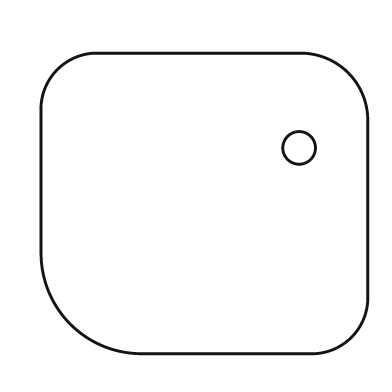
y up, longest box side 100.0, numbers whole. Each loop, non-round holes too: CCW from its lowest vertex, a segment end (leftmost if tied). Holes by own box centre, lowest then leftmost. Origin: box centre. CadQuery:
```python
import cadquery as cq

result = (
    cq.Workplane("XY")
    .moveTo(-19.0, -46.0)
    .lineTo(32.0, -46.0)
    .threePointArc((45.0, -41.0), (50.0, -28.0))
    .lineTo(50.0, 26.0)
    .threePointArc((44.0, 40.0), (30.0, 46.0))
    .lineTo(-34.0, 46.0)
    .threePointArc((-45.0, 41.0), (-50.0, 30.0))
    .lineTo(-50.0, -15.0)
    .threePointArc((-41.0, -37.0), (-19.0, -46.0))
    .close()
    .moveTo(29.0, 17.0)
    .circle(5.0)
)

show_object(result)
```